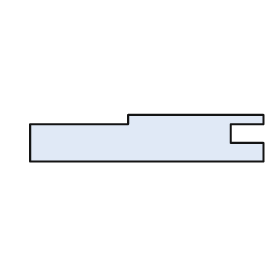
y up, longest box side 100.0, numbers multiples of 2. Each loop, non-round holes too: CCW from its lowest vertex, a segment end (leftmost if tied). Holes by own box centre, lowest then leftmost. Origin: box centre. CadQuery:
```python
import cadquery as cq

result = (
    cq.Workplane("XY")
    .moveTo(-50.0, -10.0)
    .lineTo(50.0, -10.0)
    .lineTo(50.0, -2.0)
    .lineTo(36.0, -2.0)
    .lineTo(36.0, 6.0)
    .lineTo(50.0, 6.0)
    .lineTo(50.0, 10.0)
    .lineTo(-8.0, 10.0)
    .lineTo(-8.0, 6.0)
    .lineTo(-50.0, 6.0)
    .close()
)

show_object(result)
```